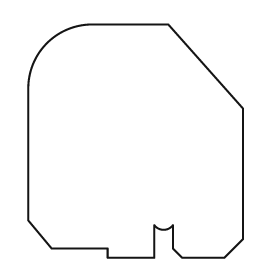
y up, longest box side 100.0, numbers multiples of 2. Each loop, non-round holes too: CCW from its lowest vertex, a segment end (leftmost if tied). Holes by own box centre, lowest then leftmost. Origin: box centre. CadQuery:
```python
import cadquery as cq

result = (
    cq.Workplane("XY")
    .moveTo(-12.0, -50.0)
    .lineTo(8.0, -50.0)
    .lineTo(8.0, -36.0)
    .threePointArc((12.0, -38.0), (16.0, -36.0))
    .lineTo(16.0, -46.0)
    .lineTo(20.0, -50.0)
    .lineTo(38.0, -50.0)
    .lineTo(46.0, -42.0)
    .lineTo(46.0, 14.0)
    .lineTo(14.0, 50.0)
    .lineTo(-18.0, 50.0)
    .threePointArc((-38.0, 42.0), (-46.0, 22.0))
    .lineTo(-46.0, -34.0)
    .lineTo(-36.0, -46.0)
    .lineTo(-12.0, -46.0)
    .close()
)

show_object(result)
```